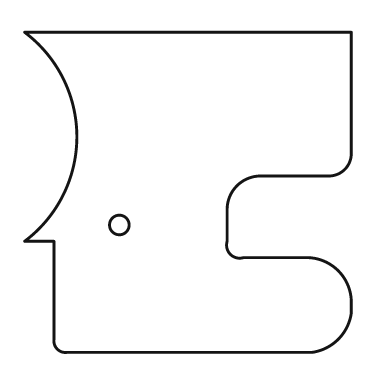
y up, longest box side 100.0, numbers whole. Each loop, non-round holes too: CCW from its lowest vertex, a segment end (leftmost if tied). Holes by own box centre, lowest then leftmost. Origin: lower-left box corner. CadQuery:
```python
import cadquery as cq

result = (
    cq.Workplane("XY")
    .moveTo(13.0, 0.0)
    .lineTo(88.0, 0.0)
    .threePointArc((96.0, 4.0), (100.0, 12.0))
    .lineTo(100.0, 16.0)
    .threePointArc((96.0, 25.0), (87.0, 29.0))
    .lineTo(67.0, 29.0)
    .threePointArc((63.0, 30.0), (62.0, 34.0))
    .lineTo(62.0, 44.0)
    .threePointArc((65.0, 51.0), (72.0, 54.0))
    .lineTo(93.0, 54.0)
    .threePointArc((98.0, 56.0), (100.0, 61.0))
    .lineTo(100.0, 98.0)
    .lineTo(0.0, 98.0)
    .threePointArc((16.0, 66.0), (0.0, 34.0))
    .lineTo(9.0, 34.0)
    .lineTo(9.0, 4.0)
    .threePointArc((10.0, 1.0), (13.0, 0.0))
    .close()
    .moveTo(29.0, 39.0)
    .circle(3.0)
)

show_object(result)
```